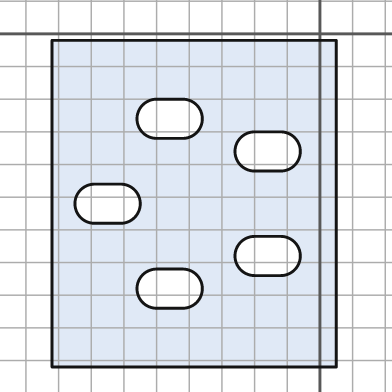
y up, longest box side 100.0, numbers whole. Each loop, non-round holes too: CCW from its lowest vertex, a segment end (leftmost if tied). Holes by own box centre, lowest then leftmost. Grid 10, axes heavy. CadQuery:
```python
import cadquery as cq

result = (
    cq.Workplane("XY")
    .moveTo(-82.0, -102.0)
    .lineTo(5.0, -102.0)
    .lineTo(5.0, -2.0)
    .lineTo(-82.0, -2.0)
    .close()
    .moveTo(-50.0, -84.0)
    .lineTo(-42.0, -84.0)
    .threePointArc((-36.0, -78.0), (-42.0, -72.0))
    .lineTo(-50.0, -72.0)
    .threePointArc((-56.0, -78.0), (-50.0, -84.0))
    .close()
    .moveTo(-20.0, -74.0)
    .lineTo(-12.0, -74.0)
    .threePointArc((-6.0, -68.0), (-12.0, -62.0))
    .lineTo(-20.0, -62.0)
    .threePointArc((-26.0, -68.0), (-20.0, -74.0))
    .close()
    .moveTo(-69.0, -58.0)
    .lineTo(-61.0, -58.0)
    .threePointArc((-55.0, -52.0), (-61.0, -46.0))
    .lineTo(-69.0, -46.0)
    .threePointArc((-75.0, -52.0), (-69.0, -58.0))
    .close()
    .moveTo(-20.0, -42.0)
    .lineTo(-12.0, -42.0)
    .threePointArc((-6.0, -36.0), (-12.0, -30.0))
    .lineTo(-20.0, -30.0)
    .threePointArc((-26.0, -36.0), (-20.0, -42.0))
    .close()
    .moveTo(-50.0, -32.0)
    .lineTo(-42.0, -32.0)
    .threePointArc((-36.0, -26.0), (-42.0, -20.0))
    .lineTo(-50.0, -20.0)
    .threePointArc((-56.0, -26.0), (-50.0, -32.0))
    .close()
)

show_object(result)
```